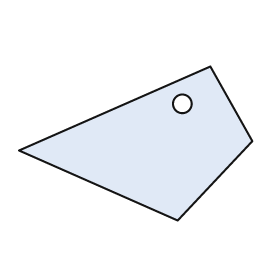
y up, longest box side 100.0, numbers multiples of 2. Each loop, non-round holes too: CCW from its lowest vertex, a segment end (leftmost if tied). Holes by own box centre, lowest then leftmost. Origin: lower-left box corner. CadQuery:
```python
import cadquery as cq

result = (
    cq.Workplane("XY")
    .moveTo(68.0, 0.0)
    .lineTo(100.0, 34.0)
    .lineTo(82.0, 66.0)
    .lineTo(0.0, 30.0)
    .close()
    .moveTo(70.0, 50.0)
    .circle(4.0)
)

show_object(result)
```